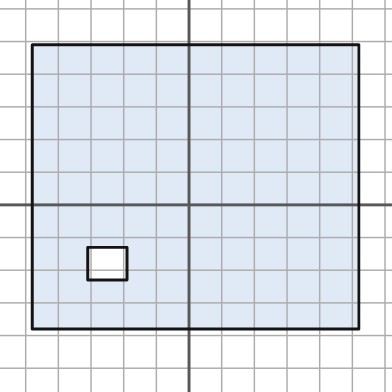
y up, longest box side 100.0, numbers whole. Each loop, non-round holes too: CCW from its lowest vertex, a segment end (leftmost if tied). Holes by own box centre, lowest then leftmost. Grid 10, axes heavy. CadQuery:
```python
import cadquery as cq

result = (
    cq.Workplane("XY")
    .moveTo(-48.0, -38.0)
    .lineTo(52.0, -38.0)
    .lineTo(52.0, 49.0)
    .lineTo(-48.0, 49.0)
    .close()
    .moveTo(-31.0, -23.0)
    .lineTo(-19.0, -23.0)
    .lineTo(-19.0, -13.0)
    .lineTo(-31.0, -13.0)
    .close()
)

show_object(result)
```